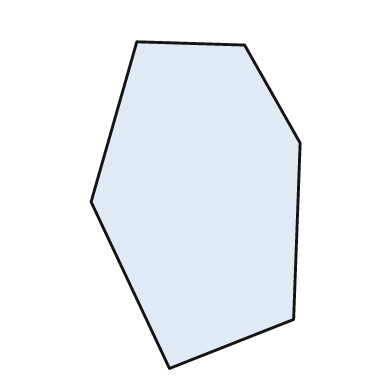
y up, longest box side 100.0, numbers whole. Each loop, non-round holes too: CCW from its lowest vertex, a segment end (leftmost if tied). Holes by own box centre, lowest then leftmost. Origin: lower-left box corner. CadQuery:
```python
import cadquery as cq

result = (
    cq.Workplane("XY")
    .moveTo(24.0, 0.0)
    .lineTo(62.0, 15.0)
    .lineTo(64.0, 69.0)
    .lineTo(47.0, 99.0)
    .lineTo(14.0, 100.0)
    .lineTo(0.0, 51.0)
    .close()
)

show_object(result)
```